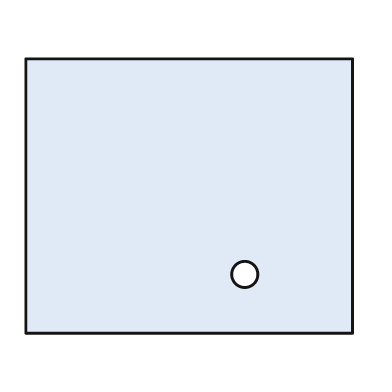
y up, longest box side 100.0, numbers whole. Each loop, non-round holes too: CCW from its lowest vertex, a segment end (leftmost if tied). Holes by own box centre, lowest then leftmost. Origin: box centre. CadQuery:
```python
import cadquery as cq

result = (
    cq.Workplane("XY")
    .moveTo(-50.0, -42.0)
    .lineTo(50.0, -42.0)
    .lineTo(50.0, 42.0)
    .lineTo(-50.0, 42.0)
    .close()
    .moveTo(17.0, -24.0)
    .circle(4.0)
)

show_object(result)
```